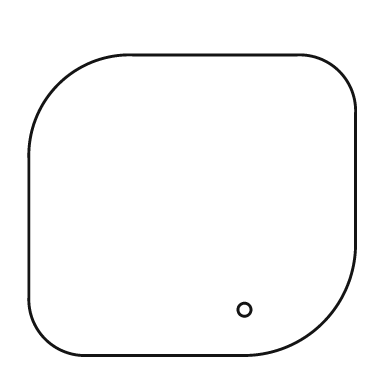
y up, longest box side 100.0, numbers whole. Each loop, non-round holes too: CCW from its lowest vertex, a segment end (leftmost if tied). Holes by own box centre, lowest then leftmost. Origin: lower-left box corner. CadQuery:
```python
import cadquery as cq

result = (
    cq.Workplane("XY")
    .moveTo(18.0, 0.0)
    .lineTo(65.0, 0.0)
    .threePointArc((90.0, 10.0), (100.0, 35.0))
    .lineTo(100.0, 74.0)
    .threePointArc((95.0, 87.0), (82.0, 92.0))
    .lineTo(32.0, 92.0)
    .threePointArc((9.0, 83.0), (0.0, 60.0))
    .lineTo(0.0, 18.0)
    .threePointArc((5.0, 5.0), (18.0, 0.0))
    .close()
    .moveTo(66.0, 14.0)
    .circle(2.0)
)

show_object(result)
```